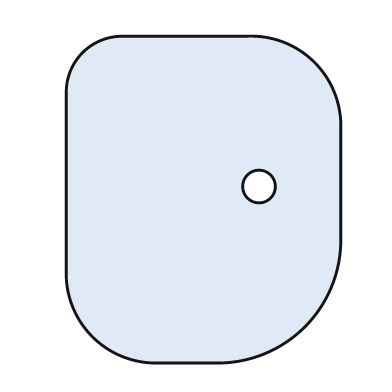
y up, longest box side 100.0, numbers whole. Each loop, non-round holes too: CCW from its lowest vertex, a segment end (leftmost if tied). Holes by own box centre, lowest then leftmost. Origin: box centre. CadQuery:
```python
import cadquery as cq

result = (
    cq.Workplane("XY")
    .moveTo(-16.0, -50.0)
    .lineTo(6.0, -50.0)
    .threePointArc((31.0, -39.0), (42.0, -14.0))
    .lineTo(42.0, 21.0)
    .threePointArc((34.0, 42.0), (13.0, 50.0))
    .lineTo(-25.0, 50.0)
    .threePointArc((-37.0, 45.0), (-42.0, 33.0))
    .lineTo(-42.0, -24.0)
    .threePointArc((-34.0, -42.0), (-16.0, -50.0))
    .close()
    .moveTo(17.0, 4.0)
    .circle(5.0)
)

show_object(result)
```